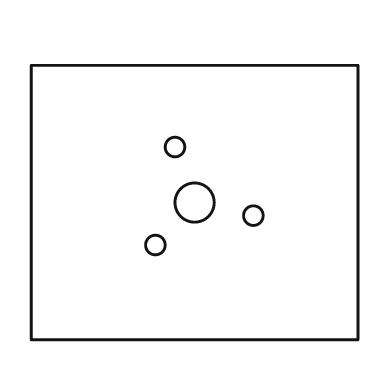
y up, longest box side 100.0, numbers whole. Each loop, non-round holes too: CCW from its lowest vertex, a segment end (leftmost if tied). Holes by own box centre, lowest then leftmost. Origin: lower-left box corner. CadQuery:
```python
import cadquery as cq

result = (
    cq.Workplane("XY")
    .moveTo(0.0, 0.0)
    .lineTo(100.0, 0.0)
    .lineTo(100.0, 84.0)
    .lineTo(0.0, 84.0)
    .close()
    .moveTo(38.0, 29.0)
    .circle(3.0)
    .moveTo(68.0, 38.0)
    .circle(3.0)
    .moveTo(50.0, 42.0)
    .circle(6.0)
    .moveTo(44.0, 59.0)
    .circle(3.0)
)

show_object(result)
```